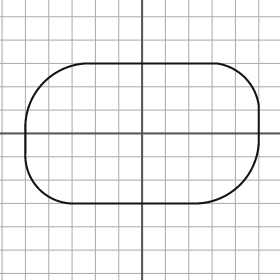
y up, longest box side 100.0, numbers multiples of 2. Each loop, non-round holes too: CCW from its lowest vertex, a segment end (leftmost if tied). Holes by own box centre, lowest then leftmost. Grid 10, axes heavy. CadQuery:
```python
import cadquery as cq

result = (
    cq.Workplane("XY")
    .moveTo(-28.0, -30.0)
    .lineTo(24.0, -30.0)
    .threePointArc((42.0, -22.0), (50.0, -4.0))
    .lineTo(50.0, 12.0)
    .threePointArc((44.0, 24.0), (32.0, 30.0))
    .lineTo(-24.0, 30.0)
    .threePointArc((-42.0, 22.0), (-50.0, 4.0))
    .lineTo(-50.0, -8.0)
    .threePointArc((-44.0, -24.0), (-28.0, -30.0))
    .close()
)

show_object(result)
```